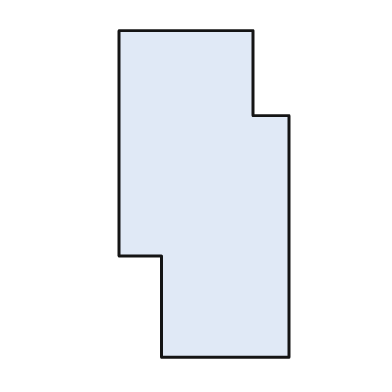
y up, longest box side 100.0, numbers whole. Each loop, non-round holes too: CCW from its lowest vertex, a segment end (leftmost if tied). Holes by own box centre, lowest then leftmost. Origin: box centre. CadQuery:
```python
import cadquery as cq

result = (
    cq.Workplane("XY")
    .moveTo(-13.0, -50.0)
    .lineTo(26.0, -50.0)
    .lineTo(26.0, 24.0)
    .lineTo(15.0, 24.0)
    .lineTo(15.0, 50.0)
    .lineTo(-26.0, 50.0)
    .lineTo(-26.0, -19.0)
    .lineTo(-13.0, -19.0)
    .close()
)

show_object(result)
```